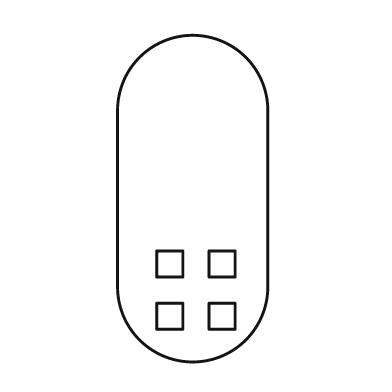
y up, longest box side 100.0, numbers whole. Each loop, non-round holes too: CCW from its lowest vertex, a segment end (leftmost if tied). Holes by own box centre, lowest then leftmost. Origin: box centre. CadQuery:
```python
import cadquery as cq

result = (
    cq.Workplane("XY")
    .moveTo(-23.0, -27.0)
    .threePointArc((0.0, -50.0), (23.0, -27.0))
    .lineTo(23.0, 27.0)
    .threePointArc((0.0, 50.0), (-23.0, 27.0))
    .close()
    .moveTo(-11.0, -40.0)
    .lineTo(-3.0, -40.0)
    .lineTo(-3.0, -32.0)
    .lineTo(-11.0, -32.0)
    .close()
    .moveTo(5.0, -40.0)
    .lineTo(13.0, -40.0)
    .lineTo(13.0, -32.0)
    .lineTo(5.0, -32.0)
    .close()
    .moveTo(-11.0, -24.0)
    .lineTo(-3.0, -24.0)
    .lineTo(-3.0, -16.0)
    .lineTo(-11.0, -16.0)
    .close()
    .moveTo(5.0, -24.0)
    .lineTo(13.0, -24.0)
    .lineTo(13.0, -16.0)
    .lineTo(5.0, -16.0)
    .close()
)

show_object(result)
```